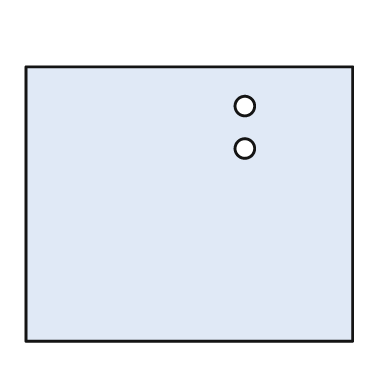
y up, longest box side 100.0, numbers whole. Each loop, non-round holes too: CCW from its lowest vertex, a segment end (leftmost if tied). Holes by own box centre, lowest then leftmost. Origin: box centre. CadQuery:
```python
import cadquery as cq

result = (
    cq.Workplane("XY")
    .moveTo(-50.0, -42.0)
    .lineTo(50.0, -42.0)
    .lineTo(50.0, 42.0)
    .lineTo(-50.0, 42.0)
    .close()
    .moveTo(17.0, 17.0)
    .circle(3.0)
    .moveTo(17.0, 30.0)
    .circle(3.0)
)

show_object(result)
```